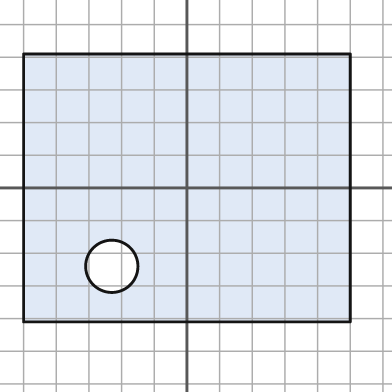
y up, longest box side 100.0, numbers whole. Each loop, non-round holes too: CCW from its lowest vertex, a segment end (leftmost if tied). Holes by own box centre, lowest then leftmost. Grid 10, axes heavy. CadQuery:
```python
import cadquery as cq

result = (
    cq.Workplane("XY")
    .moveTo(-50.0, -41.0)
    .lineTo(50.0, -41.0)
    .lineTo(50.0, 41.0)
    .lineTo(-50.0, 41.0)
    .close()
    .moveTo(-23.0, -24.0)
    .circle(8.0)
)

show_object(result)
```